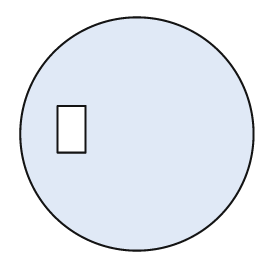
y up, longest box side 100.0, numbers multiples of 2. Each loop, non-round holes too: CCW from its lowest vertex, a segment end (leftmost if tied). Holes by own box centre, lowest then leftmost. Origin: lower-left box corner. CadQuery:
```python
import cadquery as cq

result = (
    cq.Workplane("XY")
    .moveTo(50.0, 50.0)
    .circle(50.0)
    .moveTo(16.0, 42.0)
    .lineTo(28.0, 42.0)
    .lineTo(28.0, 62.0)
    .lineTo(16.0, 62.0)
    .close()
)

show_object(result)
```